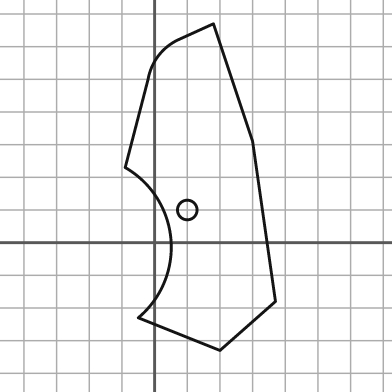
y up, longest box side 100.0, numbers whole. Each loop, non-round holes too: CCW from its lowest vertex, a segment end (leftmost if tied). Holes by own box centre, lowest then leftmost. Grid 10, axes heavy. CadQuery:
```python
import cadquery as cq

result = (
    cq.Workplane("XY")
    .moveTo(20.0, -33.0)
    .lineTo(37.0, -18.0)
    .lineTo(30.0, 31.0)
    .lineTo(18.0, 67.0)
    .lineTo(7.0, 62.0)
    .threePointArc((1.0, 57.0), (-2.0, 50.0))
    .lineTo(-9.0, 23.0)
    .threePointArc((5.0, 1.0), (-5.0, -23.0))
    .close()
    .moveTo(10.0, 10.0)
    .circle(3.0)
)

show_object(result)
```